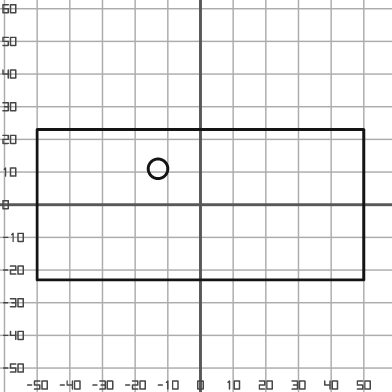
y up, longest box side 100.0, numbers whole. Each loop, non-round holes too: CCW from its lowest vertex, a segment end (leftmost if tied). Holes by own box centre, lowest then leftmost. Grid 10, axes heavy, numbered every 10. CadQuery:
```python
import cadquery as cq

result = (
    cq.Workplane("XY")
    .moveTo(-50.0, -23.0)
    .lineTo(50.0, -23.0)
    .lineTo(50.0, 23.0)
    .lineTo(-50.0, 23.0)
    .close()
    .moveTo(-13.0, 11.0)
    .circle(3.0)
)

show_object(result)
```